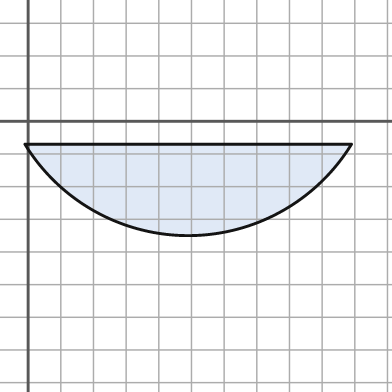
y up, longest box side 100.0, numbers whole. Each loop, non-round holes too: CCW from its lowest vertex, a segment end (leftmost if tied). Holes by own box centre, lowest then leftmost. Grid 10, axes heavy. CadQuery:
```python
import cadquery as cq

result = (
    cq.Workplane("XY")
    .moveTo(-1.0, -7.0)
    .threePointArc((49.0, -35.0), (99.0, -7.0))
    .close()
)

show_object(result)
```